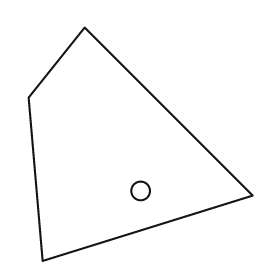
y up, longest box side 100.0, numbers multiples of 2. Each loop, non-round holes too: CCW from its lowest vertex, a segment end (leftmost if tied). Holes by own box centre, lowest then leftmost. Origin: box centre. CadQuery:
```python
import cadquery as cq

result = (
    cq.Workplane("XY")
    .moveTo(-42.0, -50.0)
    .lineTo(48.0, -22.0)
    .lineTo(-24.0, 50.0)
    .lineTo(-48.0, 20.0)
    .close()
    .moveTo(0.0, -20.0)
    .circle(4.0)
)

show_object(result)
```